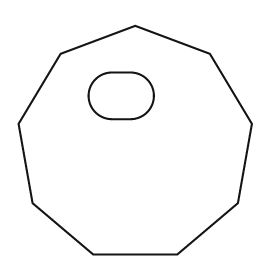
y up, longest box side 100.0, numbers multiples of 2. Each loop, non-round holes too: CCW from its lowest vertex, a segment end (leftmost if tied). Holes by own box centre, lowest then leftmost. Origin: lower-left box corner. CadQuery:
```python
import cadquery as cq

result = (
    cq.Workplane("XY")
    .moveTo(32.0, 0.0)
    .lineTo(68.0, 0.0)
    .lineTo(94.0, 22.0)
    .lineTo(100.0, 56.0)
    .lineTo(82.0, 86.0)
    .lineTo(50.0, 98.0)
    .lineTo(18.0, 86.0)
    .lineTo(0.0, 56.0)
    .lineTo(6.0, 22.0)
    .close()
    .moveTo(40.0, 58.0)
    .lineTo(48.0, 58.0)
    .threePointArc((58.0, 68.0), (48.0, 78.0))
    .lineTo(40.0, 78.0)
    .threePointArc((30.0, 68.0), (40.0, 58.0))
    .close()
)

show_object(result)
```